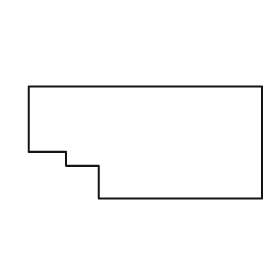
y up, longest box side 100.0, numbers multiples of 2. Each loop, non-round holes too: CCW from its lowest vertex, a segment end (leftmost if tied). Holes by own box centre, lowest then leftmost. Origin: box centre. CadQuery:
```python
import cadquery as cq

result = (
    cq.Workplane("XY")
    .moveTo(-20.0, -24.0)
    .lineTo(50.0, -24.0)
    .lineTo(50.0, 24.0)
    .lineTo(-50.0, 24.0)
    .lineTo(-50.0, -4.0)
    .lineTo(-34.0, -4.0)
    .lineTo(-34.0, -10.0)
    .lineTo(-20.0, -10.0)
    .close()
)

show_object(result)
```